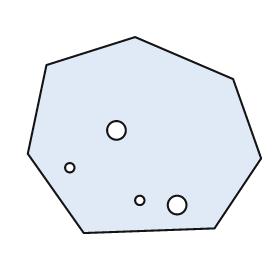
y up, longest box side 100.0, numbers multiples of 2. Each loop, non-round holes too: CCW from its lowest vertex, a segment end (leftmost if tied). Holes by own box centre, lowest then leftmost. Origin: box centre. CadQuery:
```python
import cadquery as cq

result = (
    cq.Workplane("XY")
    .moveTo(-26.0, -42.0)
    .lineTo(30.0, -40.0)
    .lineTo(50.0, -10.0)
    .lineTo(38.0, 24.0)
    .lineTo(-4.0, 42.0)
    .lineTo(-42.0, 30.0)
    .lineTo(-50.0, -8.0)
    .close()
    .moveTo(14.0, -30.0)
    .circle(4.0)
    .moveTo(-2.0, -28.0)
    .circle(2.0)
    .moveTo(-32.0, -14.0)
    .circle(2.0)
    .moveTo(-12.0, 2.0)
    .circle(4.0)
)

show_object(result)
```